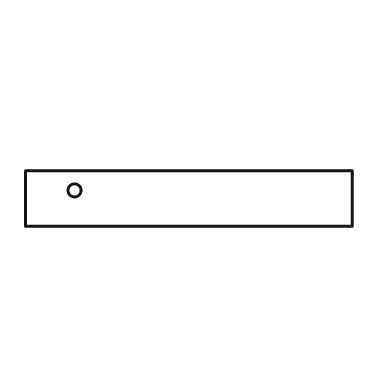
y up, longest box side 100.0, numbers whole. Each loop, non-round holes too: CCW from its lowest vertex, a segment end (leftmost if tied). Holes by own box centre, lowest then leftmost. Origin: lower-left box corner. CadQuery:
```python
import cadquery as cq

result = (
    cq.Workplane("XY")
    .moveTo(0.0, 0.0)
    .lineTo(100.0, 0.0)
    .lineTo(100.0, 17.0)
    .lineTo(0.0, 17.0)
    .close()
    .moveTo(15.0, 11.0)
    .circle(2.0)
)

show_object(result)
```